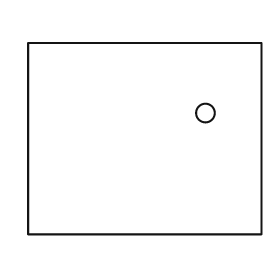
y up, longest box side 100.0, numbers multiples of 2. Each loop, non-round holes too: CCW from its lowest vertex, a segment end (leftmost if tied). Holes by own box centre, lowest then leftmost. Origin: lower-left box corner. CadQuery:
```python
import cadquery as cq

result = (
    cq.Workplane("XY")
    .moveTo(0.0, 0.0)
    .lineTo(100.0, 0.0)
    .lineTo(100.0, 82.0)
    .lineTo(0.0, 82.0)
    .close()
    .moveTo(76.0, 52.0)
    .circle(4.0)
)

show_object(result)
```